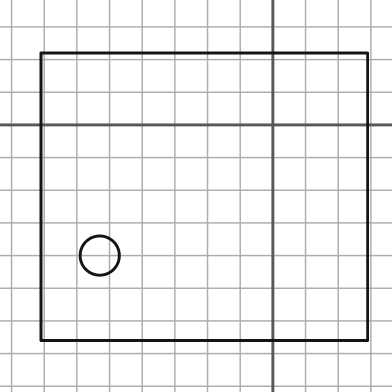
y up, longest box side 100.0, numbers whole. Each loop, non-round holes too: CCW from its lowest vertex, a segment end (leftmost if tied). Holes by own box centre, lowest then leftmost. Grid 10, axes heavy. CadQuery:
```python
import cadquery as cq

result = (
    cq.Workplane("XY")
    .moveTo(-71.0, -66.0)
    .lineTo(29.0, -66.0)
    .lineTo(29.0, 22.0)
    .lineTo(-71.0, 22.0)
    .close()
    .moveTo(-53.0, -40.0)
    .circle(6.0)
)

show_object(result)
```